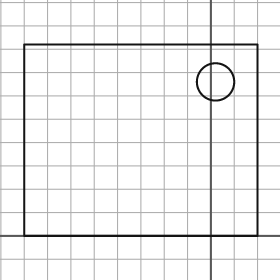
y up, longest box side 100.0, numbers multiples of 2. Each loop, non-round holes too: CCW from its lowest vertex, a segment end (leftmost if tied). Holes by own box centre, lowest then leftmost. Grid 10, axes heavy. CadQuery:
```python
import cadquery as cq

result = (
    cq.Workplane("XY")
    .moveTo(-80.0, 0.0)
    .lineTo(20.0, 0.0)
    .lineTo(20.0, 82.0)
    .lineTo(-80.0, 82.0)
    .close()
    .moveTo(2.0, 66.0)
    .circle(8.0)
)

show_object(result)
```